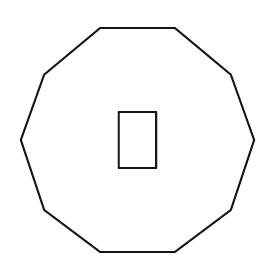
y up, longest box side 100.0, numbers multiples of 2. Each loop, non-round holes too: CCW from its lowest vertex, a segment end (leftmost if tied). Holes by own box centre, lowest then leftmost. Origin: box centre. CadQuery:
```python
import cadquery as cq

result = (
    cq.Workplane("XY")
    .moveTo(-16.0, -48.0)
    .lineTo(16.0, -48.0)
    .lineTo(40.0, -30.0)
    .lineTo(50.0, 0.0)
    .lineTo(40.0, 28.0)
    .lineTo(16.0, 48.0)
    .lineTo(-16.0, 48.0)
    .lineTo(-40.0, 28.0)
    .lineTo(-50.0, 0.0)
    .lineTo(-40.0, -30.0)
    .close()
    .moveTo(-8.0, -12.0)
    .lineTo(8.0, -12.0)
    .lineTo(8.0, 12.0)
    .lineTo(-8.0, 12.0)
    .close()
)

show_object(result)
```